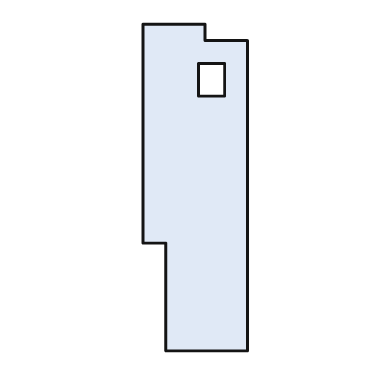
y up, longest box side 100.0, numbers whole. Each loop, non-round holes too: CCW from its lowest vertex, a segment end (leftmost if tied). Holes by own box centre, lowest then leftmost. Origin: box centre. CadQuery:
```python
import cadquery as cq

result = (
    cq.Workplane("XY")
    .moveTo(-9.0, -50.0)
    .lineTo(16.0, -50.0)
    .lineTo(16.0, 45.0)
    .lineTo(3.0, 45.0)
    .lineTo(3.0, 50.0)
    .lineTo(-16.0, 50.0)
    .lineTo(-16.0, -17.0)
    .lineTo(-9.0, -17.0)
    .close()
    .moveTo(1.0, 28.0)
    .lineTo(9.0, 28.0)
    .lineTo(9.0, 38.0)
    .lineTo(1.0, 38.0)
    .close()
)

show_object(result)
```